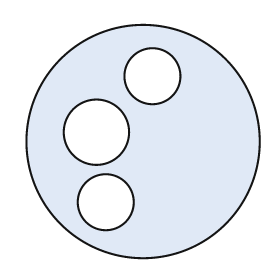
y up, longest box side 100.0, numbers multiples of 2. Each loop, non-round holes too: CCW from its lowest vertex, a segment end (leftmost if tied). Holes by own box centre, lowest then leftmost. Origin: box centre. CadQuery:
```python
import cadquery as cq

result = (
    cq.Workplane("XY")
    .moveTo(0.0, 0.0)
    .circle(50.0)
    .moveTo(-16.0, -26.0)
    .circle(12.0)
    .moveTo(-20.0, 4.0)
    .circle(14.0)
    .moveTo(4.0, 28.0)
    .circle(12.0)
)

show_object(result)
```